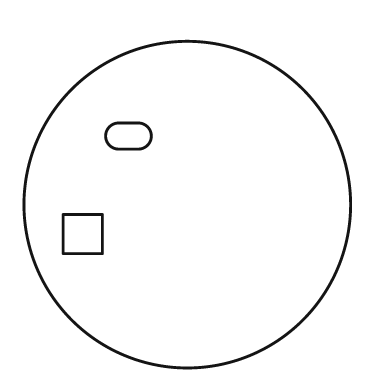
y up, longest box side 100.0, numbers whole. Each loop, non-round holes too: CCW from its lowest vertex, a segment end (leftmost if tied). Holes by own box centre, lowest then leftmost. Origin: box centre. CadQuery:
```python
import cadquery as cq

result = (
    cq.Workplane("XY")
    .moveTo(0.0, 0.0)
    .circle(50.0)
    .moveTo(-38.0, -15.0)
    .lineTo(-26.0, -15.0)
    .lineTo(-26.0, -3.0)
    .lineTo(-38.0, -3.0)
    .close()
    .moveTo(-21.0, 17.0)
    .lineTo(-15.0, 17.0)
    .threePointArc((-11.0, 21.0), (-15.0, 25.0))
    .lineTo(-21.0, 25.0)
    .threePointArc((-25.0, 21.0), (-21.0, 17.0))
    .close()
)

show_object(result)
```